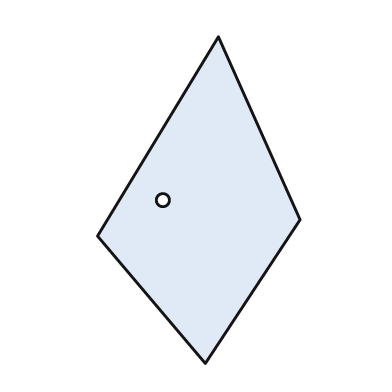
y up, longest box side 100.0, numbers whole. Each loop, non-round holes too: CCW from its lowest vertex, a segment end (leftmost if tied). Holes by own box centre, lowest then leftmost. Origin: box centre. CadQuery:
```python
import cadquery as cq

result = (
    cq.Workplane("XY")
    .moveTo(2.0, -50.0)
    .lineTo(31.0, -6.0)
    .lineTo(6.0, 50.0)
    .lineTo(-31.0, -11.0)
    .close()
    .moveTo(-11.0, 0.0)
    .circle(2.0)
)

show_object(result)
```